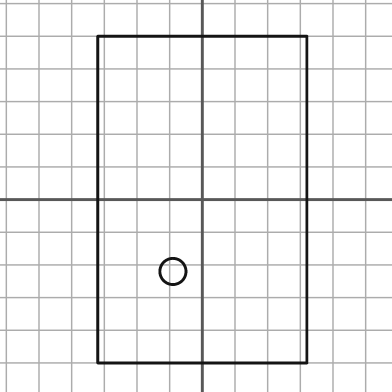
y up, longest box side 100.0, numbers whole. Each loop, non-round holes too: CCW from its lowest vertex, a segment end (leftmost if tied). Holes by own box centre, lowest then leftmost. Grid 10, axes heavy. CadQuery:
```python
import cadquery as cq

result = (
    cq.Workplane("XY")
    .moveTo(-32.0, -50.0)
    .lineTo(32.0, -50.0)
    .lineTo(32.0, 50.0)
    .lineTo(-32.0, 50.0)
    .close()
    .moveTo(-9.0, -22.0)
    .circle(4.0)
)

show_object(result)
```